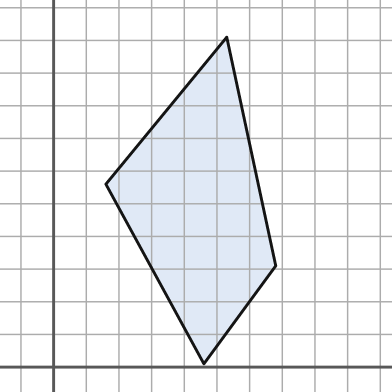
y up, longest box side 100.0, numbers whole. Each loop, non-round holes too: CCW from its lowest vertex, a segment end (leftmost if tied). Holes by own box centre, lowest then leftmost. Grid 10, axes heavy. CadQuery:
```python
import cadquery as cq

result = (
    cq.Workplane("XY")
    .moveTo(46.0, 1.0)
    .lineTo(68.0, 31.0)
    .lineTo(53.0, 101.0)
    .lineTo(16.0, 56.0)
    .close()
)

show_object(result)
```